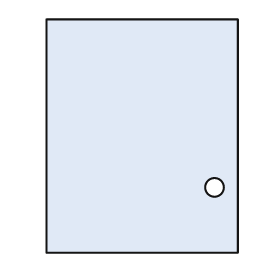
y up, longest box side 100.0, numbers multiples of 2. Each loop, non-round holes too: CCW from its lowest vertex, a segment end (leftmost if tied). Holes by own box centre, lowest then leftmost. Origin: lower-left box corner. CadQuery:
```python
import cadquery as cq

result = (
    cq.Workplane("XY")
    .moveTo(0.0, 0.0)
    .lineTo(82.0, 0.0)
    .lineTo(82.0, 100.0)
    .lineTo(0.0, 100.0)
    .close()
    .moveTo(72.0, 28.0)
    .circle(4.0)
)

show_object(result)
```